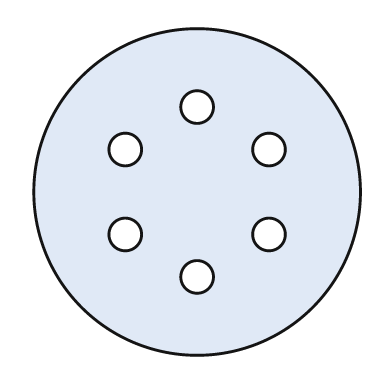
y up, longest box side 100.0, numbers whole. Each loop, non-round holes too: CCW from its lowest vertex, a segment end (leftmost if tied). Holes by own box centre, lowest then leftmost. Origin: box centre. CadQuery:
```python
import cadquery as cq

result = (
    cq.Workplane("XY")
    .moveTo(0.0, 0.0)
    .circle(50.0)
    .moveTo(0.0, -26.0)
    .circle(5.0)
    .moveTo(-22.0, -13.0)
    .circle(5.0)
    .moveTo(22.0, -13.0)
    .circle(5.0)
    .moveTo(-22.0, 13.0)
    .circle(5.0)
    .moveTo(22.0, 13.0)
    .circle(5.0)
    .moveTo(0.0, 26.0)
    .circle(5.0)
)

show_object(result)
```